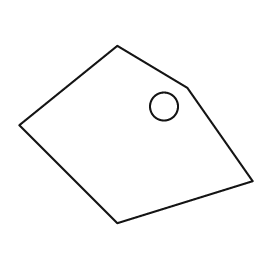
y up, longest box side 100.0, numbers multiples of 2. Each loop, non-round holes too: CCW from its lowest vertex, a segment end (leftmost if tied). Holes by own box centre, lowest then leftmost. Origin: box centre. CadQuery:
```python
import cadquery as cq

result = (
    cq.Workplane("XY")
    .moveTo(-8.0, -38.0)
    .lineTo(50.0, -20.0)
    .lineTo(22.0, 20.0)
    .lineTo(-8.0, 38.0)
    .lineTo(-50.0, 4.0)
    .close()
    .moveTo(12.0, 12.0)
    .circle(6.0)
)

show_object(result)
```